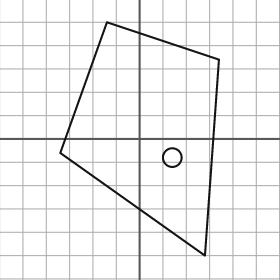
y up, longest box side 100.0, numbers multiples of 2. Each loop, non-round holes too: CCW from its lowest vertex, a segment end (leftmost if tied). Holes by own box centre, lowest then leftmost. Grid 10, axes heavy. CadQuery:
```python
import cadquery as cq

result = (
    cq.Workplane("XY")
    .moveTo(28.0, -50.0)
    .lineTo(34.0, 34.0)
    .lineTo(-14.0, 50.0)
    .lineTo(-34.0, -6.0)
    .close()
    .moveTo(14.0, -8.0)
    .circle(4.0)
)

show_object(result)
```